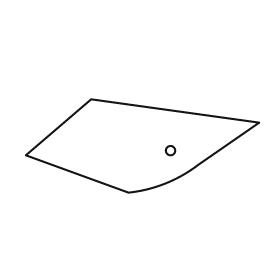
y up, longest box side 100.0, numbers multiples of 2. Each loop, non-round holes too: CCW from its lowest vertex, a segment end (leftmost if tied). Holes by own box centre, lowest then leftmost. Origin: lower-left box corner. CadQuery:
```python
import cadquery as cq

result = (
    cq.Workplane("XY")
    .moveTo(44.0, 0.0)
    .threePointArc((60.0, 4.0), (74.0, 12.0))
    .lineTo(100.0, 30.0)
    .lineTo(28.0, 40.0)
    .lineTo(0.0, 16.0)
    .close()
    .moveTo(62.0, 18.0)
    .circle(2.0)
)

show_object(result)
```